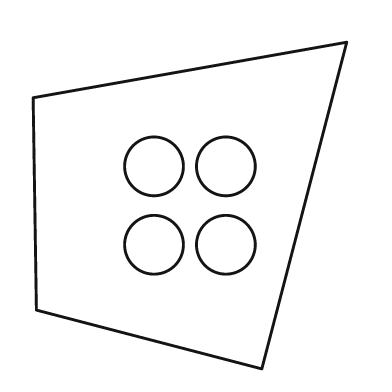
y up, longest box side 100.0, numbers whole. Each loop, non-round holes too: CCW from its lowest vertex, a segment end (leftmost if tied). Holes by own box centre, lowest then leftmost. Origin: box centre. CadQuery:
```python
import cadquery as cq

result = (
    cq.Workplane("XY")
    .moveTo(22.0, -50.0)
    .lineTo(48.0, 50.0)
    .lineTo(-48.0, 33.0)
    .lineTo(-47.0, -32.0)
    .close()
    .moveTo(-11.0, -12.0)
    .circle(9.0)
    .moveTo(11.0, -12.0)
    .circle(9.0)
    .moveTo(-11.0, 12.0)
    .circle(9.0)
    .moveTo(11.0, 12.0)
    .circle(9.0)
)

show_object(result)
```